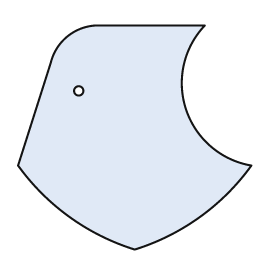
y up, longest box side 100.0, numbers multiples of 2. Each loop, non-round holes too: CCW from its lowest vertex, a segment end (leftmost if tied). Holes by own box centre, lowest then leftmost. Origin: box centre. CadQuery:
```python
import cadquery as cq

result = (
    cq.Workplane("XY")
    .moveTo(0.0, -48.0)
    .threePointArc((28.0, -34.0), (50.0, -12.0))
    .threePointArc((22.0, 12.0), (30.0, 48.0))
    .lineTo(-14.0, 48.0)
    .threePointArc((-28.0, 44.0), (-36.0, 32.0))
    .lineTo(-50.0, -12.0)
    .threePointArc((-28.0, -34.0), (0.0, -48.0))
    .close()
    .moveTo(-24.0, 20.0)
    .circle(2.0)
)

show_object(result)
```